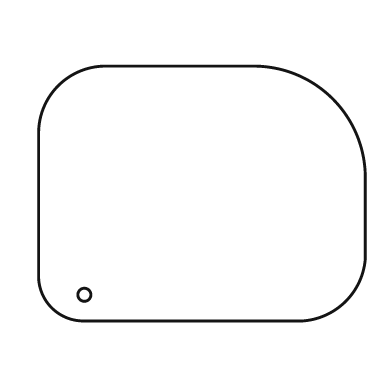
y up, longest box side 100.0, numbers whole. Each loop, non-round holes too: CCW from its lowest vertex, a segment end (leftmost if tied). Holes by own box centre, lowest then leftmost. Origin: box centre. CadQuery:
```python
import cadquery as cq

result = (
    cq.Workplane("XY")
    .moveTo(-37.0, -39.0)
    .lineTo(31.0, -39.0)
    .threePointArc((44.0, -33.0), (50.0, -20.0))
    .lineTo(50.0, 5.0)
    .threePointArc((40.0, 29.0), (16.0, 39.0))
    .lineTo(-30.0, 39.0)
    .threePointArc((-44.0, 33.0), (-50.0, 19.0))
    .lineTo(-50.0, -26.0)
    .threePointArc((-46.0, -35.0), (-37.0, -39.0))
    .close()
    .moveTo(-36.0, -31.0)
    .circle(2.0)
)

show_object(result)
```